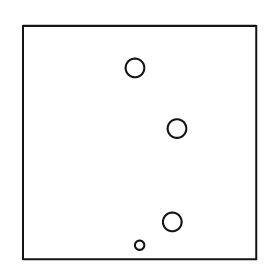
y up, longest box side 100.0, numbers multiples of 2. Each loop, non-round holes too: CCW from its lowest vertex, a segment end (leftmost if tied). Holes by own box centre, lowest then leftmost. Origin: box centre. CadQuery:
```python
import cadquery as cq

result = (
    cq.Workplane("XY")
    .moveTo(-50.0, -50.0)
    .lineTo(50.0, -50.0)
    .lineTo(50.0, 50.0)
    .lineTo(-50.0, 50.0)
    .close()
    .moveTo(0.0, -44.0)
    .circle(2.0)
    .moveTo(14.0, -34.0)
    .circle(4.0)
    .moveTo(16.0, 6.0)
    .circle(4.0)
    .moveTo(-2.0, 32.0)
    .circle(4.0)
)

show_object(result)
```